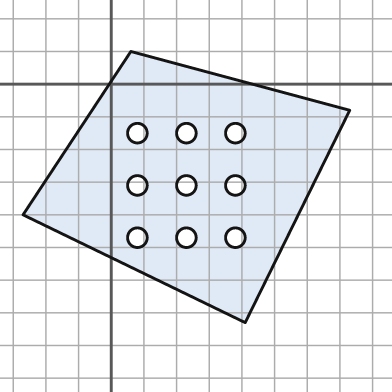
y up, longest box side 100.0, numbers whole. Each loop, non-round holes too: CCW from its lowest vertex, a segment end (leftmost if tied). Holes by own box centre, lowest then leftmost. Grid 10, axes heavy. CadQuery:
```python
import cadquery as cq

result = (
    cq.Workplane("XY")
    .moveTo(41.0, -73.0)
    .lineTo(73.0, -8.0)
    .lineTo(6.0, 10.0)
    .lineTo(-27.0, -40.0)
    .close()
    .moveTo(8.0, -47.0)
    .circle(3.0)
    .moveTo(23.0, -47.0)
    .circle(3.0)
    .moveTo(38.0, -47.0)
    .circle(3.0)
    .moveTo(8.0, -31.0)
    .circle(3.0)
    .moveTo(23.0, -31.0)
    .circle(3.0)
    .moveTo(38.0, -31.0)
    .circle(3.0)
    .moveTo(8.0, -15.0)
    .circle(3.0)
    .moveTo(23.0, -15.0)
    .circle(3.0)
    .moveTo(38.0, -15.0)
    .circle(3.0)
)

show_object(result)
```